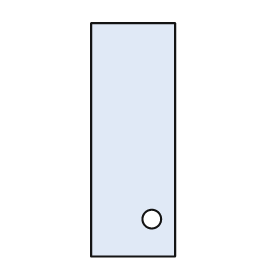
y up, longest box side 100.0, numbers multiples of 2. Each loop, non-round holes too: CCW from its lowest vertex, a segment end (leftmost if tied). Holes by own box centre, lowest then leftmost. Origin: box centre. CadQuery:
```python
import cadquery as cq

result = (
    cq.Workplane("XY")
    .moveTo(-18.0, -50.0)
    .lineTo(18.0, -50.0)
    .lineTo(18.0, 50.0)
    .lineTo(-18.0, 50.0)
    .close()
    .moveTo(8.0, -34.0)
    .circle(4.0)
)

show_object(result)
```